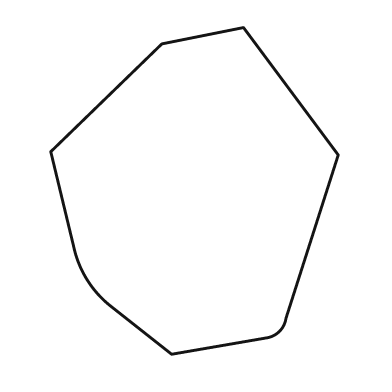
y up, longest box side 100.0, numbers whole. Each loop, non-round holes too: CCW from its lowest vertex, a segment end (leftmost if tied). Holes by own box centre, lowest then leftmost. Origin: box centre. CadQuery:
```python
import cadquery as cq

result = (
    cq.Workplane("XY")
    .moveTo(-7.0, -50.0)
    .lineTo(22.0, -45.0)
    .threePointArc((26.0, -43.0), (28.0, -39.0))
    .lineTo(44.0, 11.0)
    .lineTo(15.0, 50.0)
    .lineTo(-10.0, 45.0)
    .lineTo(-44.0, 12.0)
    .lineTo(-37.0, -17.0)
    .threePointArc((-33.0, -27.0), (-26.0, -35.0))
    .close()
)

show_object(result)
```